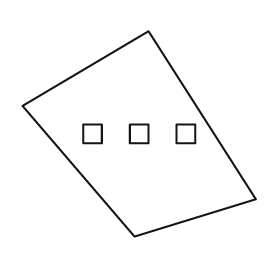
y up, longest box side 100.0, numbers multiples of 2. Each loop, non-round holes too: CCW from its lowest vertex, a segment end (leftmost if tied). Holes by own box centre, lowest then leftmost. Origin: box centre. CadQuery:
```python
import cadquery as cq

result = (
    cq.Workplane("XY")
    .moveTo(-2.0, -44.0)
    .lineTo(50.0, -28.0)
    .lineTo(4.0, 44.0)
    .lineTo(-50.0, 12.0)
    .close()
    .moveTo(-24.0, -4.0)
    .lineTo(-16.0, -4.0)
    .lineTo(-16.0, 4.0)
    .lineTo(-24.0, 4.0)
    .close()
    .moveTo(-4.0, -4.0)
    .lineTo(4.0, -4.0)
    .lineTo(4.0, 4.0)
    .lineTo(-4.0, 4.0)
    .close()
    .moveTo(16.0, -4.0)
    .lineTo(24.0, -4.0)
    .lineTo(24.0, 4.0)
    .lineTo(16.0, 4.0)
    .close()
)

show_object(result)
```